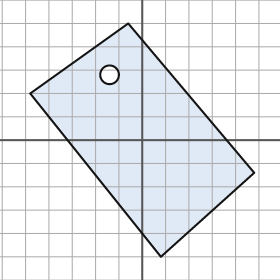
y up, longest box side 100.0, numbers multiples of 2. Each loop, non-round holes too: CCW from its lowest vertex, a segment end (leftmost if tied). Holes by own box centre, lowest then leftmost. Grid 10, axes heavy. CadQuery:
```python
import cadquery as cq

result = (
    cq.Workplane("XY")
    .moveTo(8.0, -50.0)
    .lineTo(48.0, -14.0)
    .lineTo(-6.0, 50.0)
    .lineTo(-48.0, 20.0)
    .close()
    .moveTo(-14.0, 28.0)
    .circle(4.0)
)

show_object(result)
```